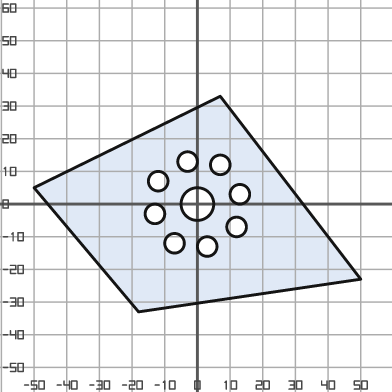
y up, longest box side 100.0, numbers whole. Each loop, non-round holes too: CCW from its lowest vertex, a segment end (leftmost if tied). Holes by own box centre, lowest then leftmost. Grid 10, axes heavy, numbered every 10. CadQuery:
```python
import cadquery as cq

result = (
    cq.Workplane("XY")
    .moveTo(-18.0, -33.0)
    .lineTo(50.0, -23.0)
    .lineTo(7.0, 33.0)
    .lineTo(-50.0, 5.0)
    .close()
    .moveTo(3.0, -13.0)
    .circle(3.0)
    .moveTo(-7.0, -12.0)
    .circle(3.0)
    .moveTo(12.0, -7.0)
    .circle(3.0)
    .moveTo(-13.0, -3.0)
    .circle(3.0)
    .moveTo(0.0, 0.0)
    .circle(5.0)
    .moveTo(13.0, 3.0)
    .circle(3.0)
    .moveTo(-12.0, 7.0)
    .circle(3.0)
    .moveTo(7.0, 12.0)
    .circle(3.0)
    .moveTo(-3.0, 13.0)
    .circle(3.0)
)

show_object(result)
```